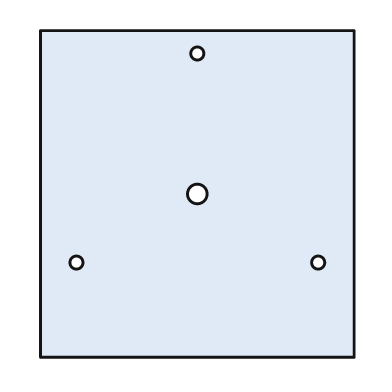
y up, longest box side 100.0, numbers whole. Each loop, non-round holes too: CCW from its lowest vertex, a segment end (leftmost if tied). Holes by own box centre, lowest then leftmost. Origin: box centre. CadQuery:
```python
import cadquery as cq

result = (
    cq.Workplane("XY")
    .moveTo(-48.0, -50.0)
    .lineTo(48.0, -50.0)
    .lineTo(48.0, 50.0)
    .lineTo(-48.0, 50.0)
    .close()
    .moveTo(-37.0, -21.0)
    .circle(2.0)
    .moveTo(37.0, -21.0)
    .circle(2.0)
    .moveTo(0.0, 0.0)
    .circle(3.0)
    .moveTo(0.0, 43.0)
    .circle(2.0)
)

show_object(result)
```